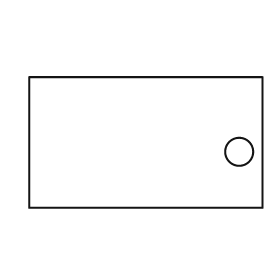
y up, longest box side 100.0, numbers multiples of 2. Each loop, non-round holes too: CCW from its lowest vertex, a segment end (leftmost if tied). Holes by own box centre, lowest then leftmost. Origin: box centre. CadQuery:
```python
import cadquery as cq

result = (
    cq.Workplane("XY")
    .moveTo(-50.0, -28.0)
    .lineTo(50.0, -28.0)
    .lineTo(50.0, 28.0)
    .lineTo(-50.0, 28.0)
    .close()
    .moveTo(40.0, -4.0)
    .circle(6.0)
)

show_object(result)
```